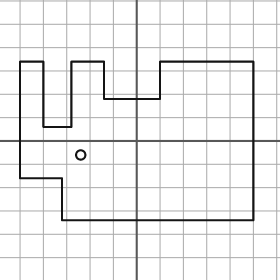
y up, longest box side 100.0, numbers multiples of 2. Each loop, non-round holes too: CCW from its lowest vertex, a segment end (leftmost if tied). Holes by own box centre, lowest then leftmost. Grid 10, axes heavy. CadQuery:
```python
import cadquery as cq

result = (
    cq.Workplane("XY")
    .moveTo(-32.0, -34.0)
    .lineTo(50.0, -34.0)
    .lineTo(50.0, 34.0)
    .lineTo(10.0, 34.0)
    .lineTo(10.0, 18.0)
    .lineTo(-14.0, 18.0)
    .lineTo(-14.0, 34.0)
    .lineTo(-28.0, 34.0)
    .lineTo(-28.0, 6.0)
    .lineTo(-40.0, 6.0)
    .lineTo(-40.0, 34.0)
    .lineTo(-50.0, 34.0)
    .lineTo(-50.0, -16.0)
    .lineTo(-32.0, -16.0)
    .close()
    .moveTo(-24.0, -6.0)
    .circle(2.0)
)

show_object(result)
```